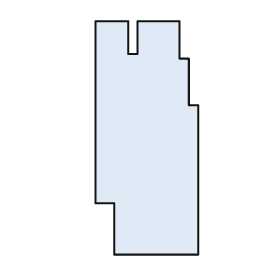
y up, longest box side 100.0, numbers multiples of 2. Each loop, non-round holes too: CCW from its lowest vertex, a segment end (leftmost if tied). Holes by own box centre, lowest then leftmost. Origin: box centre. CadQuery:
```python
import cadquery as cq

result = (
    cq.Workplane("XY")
    .moveTo(-14.0, -50.0)
    .lineTo(22.0, -50.0)
    .lineTo(22.0, 14.0)
    .lineTo(18.0, 14.0)
    .lineTo(18.0, 34.0)
    .lineTo(14.0, 34.0)
    .lineTo(14.0, 50.0)
    .lineTo(-4.0, 50.0)
    .lineTo(-4.0, 36.0)
    .lineTo(-8.0, 36.0)
    .lineTo(-8.0, 50.0)
    .lineTo(-22.0, 50.0)
    .lineTo(-22.0, -28.0)
    .lineTo(-14.0, -28.0)
    .close()
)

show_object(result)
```